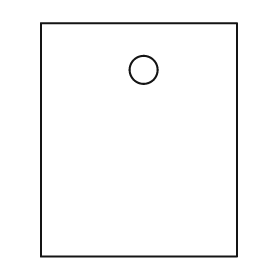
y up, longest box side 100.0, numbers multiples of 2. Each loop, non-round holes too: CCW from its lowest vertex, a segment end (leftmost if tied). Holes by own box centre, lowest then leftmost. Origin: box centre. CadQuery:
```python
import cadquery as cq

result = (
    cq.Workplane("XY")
    .moveTo(-42.0, -50.0)
    .lineTo(42.0, -50.0)
    .lineTo(42.0, 50.0)
    .lineTo(-42.0, 50.0)
    .close()
    .moveTo(2.0, 30.0)
    .circle(6.0)
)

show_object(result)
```